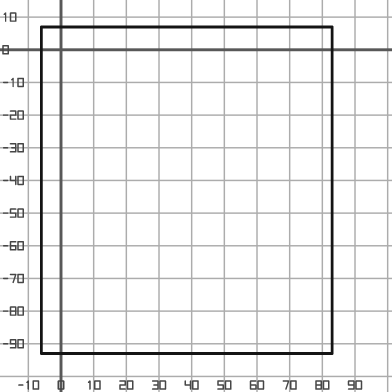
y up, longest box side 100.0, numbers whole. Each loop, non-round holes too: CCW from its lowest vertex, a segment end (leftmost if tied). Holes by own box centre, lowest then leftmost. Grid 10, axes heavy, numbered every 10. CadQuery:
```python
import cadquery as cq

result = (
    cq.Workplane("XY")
    .moveTo(-6.0, -93.0)
    .lineTo(83.0, -93.0)
    .lineTo(83.0, 7.0)
    .lineTo(-6.0, 7.0)
    .close()
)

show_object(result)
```